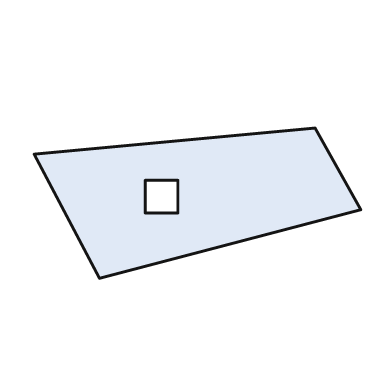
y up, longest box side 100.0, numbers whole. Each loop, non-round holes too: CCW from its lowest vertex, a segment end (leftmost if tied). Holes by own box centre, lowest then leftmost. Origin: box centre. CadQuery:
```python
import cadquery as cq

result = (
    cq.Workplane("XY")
    .moveTo(-30.0, -23.0)
    .lineTo(50.0, -2.0)
    .lineTo(36.0, 23.0)
    .lineTo(-50.0, 15.0)
    .close()
    .moveTo(-16.0, -3.0)
    .lineTo(-6.0, -3.0)
    .lineTo(-6.0, 7.0)
    .lineTo(-16.0, 7.0)
    .close()
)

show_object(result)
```